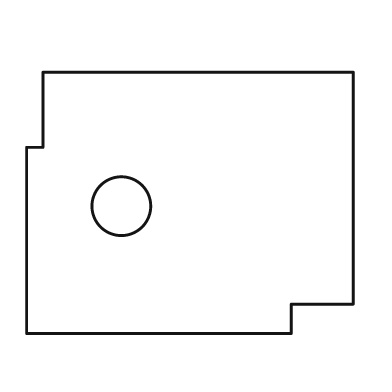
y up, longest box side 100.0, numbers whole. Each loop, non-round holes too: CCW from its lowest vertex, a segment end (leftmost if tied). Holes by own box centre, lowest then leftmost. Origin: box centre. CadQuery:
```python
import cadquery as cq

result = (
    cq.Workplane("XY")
    .moveTo(-50.0, -40.0)
    .lineTo(31.0, -40.0)
    .lineTo(31.0, -31.0)
    .lineTo(50.0, -31.0)
    .lineTo(50.0, 40.0)
    .lineTo(-45.0, 40.0)
    .lineTo(-45.0, 17.0)
    .lineTo(-50.0, 17.0)
    .close()
    .moveTo(-21.0, -1.0)
    .circle(9.0)
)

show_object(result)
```